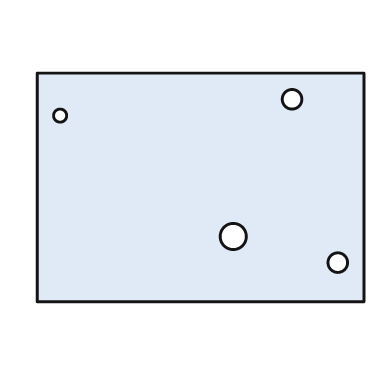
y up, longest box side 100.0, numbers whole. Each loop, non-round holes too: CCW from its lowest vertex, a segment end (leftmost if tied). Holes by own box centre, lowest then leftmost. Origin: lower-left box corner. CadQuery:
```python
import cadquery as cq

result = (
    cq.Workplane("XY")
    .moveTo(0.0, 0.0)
    .lineTo(100.0, 0.0)
    .lineTo(100.0, 70.0)
    .lineTo(0.0, 70.0)
    .close()
    .moveTo(92.0, 12.0)
    .circle(3.0)
    .moveTo(60.0, 20.0)
    .circle(4.0)
    .moveTo(7.0, 57.0)
    .circle(2.0)
    .moveTo(78.0, 62.0)
    .circle(3.0)
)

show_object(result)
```